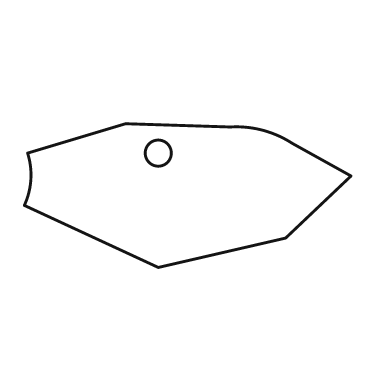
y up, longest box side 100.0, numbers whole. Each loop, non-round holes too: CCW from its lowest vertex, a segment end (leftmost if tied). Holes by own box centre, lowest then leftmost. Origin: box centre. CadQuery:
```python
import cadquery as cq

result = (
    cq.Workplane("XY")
    .moveTo(-9.0, -22.0)
    .lineTo(30.0, -13.0)
    .lineTo(50.0, 6.0)
    .lineTo(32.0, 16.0)
    .threePointArc((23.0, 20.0), (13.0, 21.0))
    .lineTo(-19.0, 22.0)
    .lineTo(-49.0, 13.0)
    .threePointArc((-48.0, 5.0), (-50.0, -3.0))
    .close()
    .moveTo(-9.0, 13.0)
    .circle(4.0)
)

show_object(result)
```